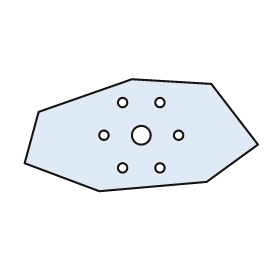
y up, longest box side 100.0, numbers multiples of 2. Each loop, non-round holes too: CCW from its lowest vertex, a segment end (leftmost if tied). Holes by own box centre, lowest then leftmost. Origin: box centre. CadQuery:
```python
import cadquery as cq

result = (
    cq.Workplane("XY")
    .moveTo(-18.0, -24.0)
    .lineTo(28.0, -20.0)
    .lineTo(50.0, -4.0)
    .lineTo(30.0, 22.0)
    .lineTo(-4.0, 24.0)
    .lineTo(-44.0, 10.0)
    .lineTo(-50.0, -12.0)
    .close()
    .moveTo(-8.0, -14.0)
    .circle(2.0)
    .moveTo(8.0, -14.0)
    .circle(2.0)
    .moveTo(-16.0, 0.0)
    .circle(2.0)
    .moveTo(0.0, 0.0)
    .circle(4.0)
    .moveTo(16.0, 0.0)
    .circle(2.0)
    .moveTo(-8.0, 14.0)
    .circle(2.0)
    .moveTo(8.0, 14.0)
    .circle(2.0)
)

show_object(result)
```